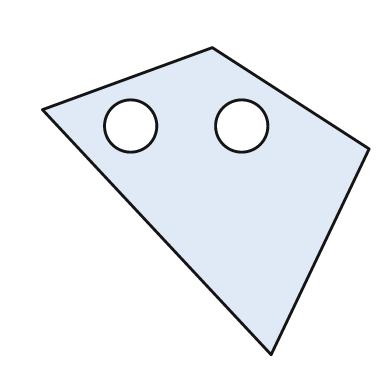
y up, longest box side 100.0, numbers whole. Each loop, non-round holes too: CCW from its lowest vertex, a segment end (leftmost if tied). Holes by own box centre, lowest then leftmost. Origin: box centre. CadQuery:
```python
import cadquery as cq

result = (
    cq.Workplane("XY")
    .moveTo(20.0, -47.0)
    .lineTo(50.0, 16.0)
    .lineTo(2.0, 47.0)
    .lineTo(-50.0, 28.0)
    .close()
    .moveTo(-23.0, 23.0)
    .circle(8.0)
    .moveTo(11.0, 23.0)
    .circle(8.0)
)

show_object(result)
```